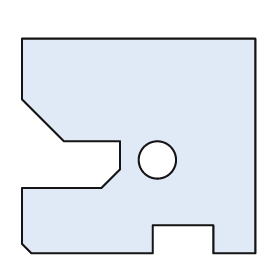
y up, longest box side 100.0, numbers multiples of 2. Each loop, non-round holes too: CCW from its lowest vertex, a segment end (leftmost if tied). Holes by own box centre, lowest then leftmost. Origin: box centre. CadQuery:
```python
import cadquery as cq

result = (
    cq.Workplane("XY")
    .moveTo(-46.0, -46.0)
    .lineTo(6.0, -46.0)
    .lineTo(6.0, -34.0)
    .lineTo(32.0, -34.0)
    .lineTo(32.0, -46.0)
    .lineTo(50.0, -46.0)
    .lineTo(50.0, 46.0)
    .lineTo(-50.0, 46.0)
    .lineTo(-50.0, 20.0)
    .lineTo(-32.0, 2.0)
    .lineTo(-8.0, 2.0)
    .lineTo(-8.0, -10.0)
    .lineTo(-16.0, -18.0)
    .lineTo(-50.0, -18.0)
    .lineTo(-50.0, -42.0)
    .close()
    .moveTo(8.0, -6.0)
    .circle(8.0)
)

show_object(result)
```